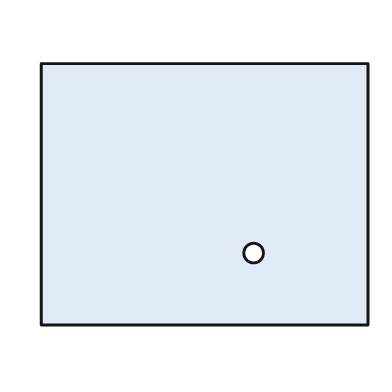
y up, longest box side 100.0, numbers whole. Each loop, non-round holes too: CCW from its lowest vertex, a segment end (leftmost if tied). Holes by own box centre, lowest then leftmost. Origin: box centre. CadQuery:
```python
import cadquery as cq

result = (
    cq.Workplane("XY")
    .moveTo(-50.0, -40.0)
    .lineTo(50.0, -40.0)
    .lineTo(50.0, 40.0)
    .lineTo(-50.0, 40.0)
    .close()
    .moveTo(15.0, -18.0)
    .circle(3.0)
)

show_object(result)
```